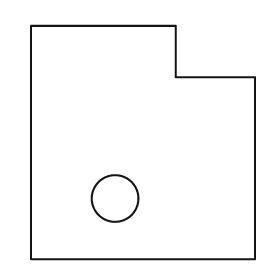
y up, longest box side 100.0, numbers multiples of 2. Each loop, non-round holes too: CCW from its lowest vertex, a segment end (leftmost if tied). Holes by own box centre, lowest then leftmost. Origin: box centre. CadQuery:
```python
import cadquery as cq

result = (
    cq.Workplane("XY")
    .moveTo(-48.0, -50.0)
    .lineTo(48.0, -50.0)
    .lineTo(48.0, 28.0)
    .lineTo(14.0, 28.0)
    .lineTo(14.0, 50.0)
    .lineTo(-48.0, 50.0)
    .close()
    .moveTo(-12.0, -24.0)
    .circle(10.0)
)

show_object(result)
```